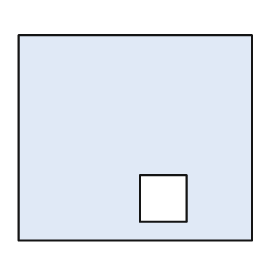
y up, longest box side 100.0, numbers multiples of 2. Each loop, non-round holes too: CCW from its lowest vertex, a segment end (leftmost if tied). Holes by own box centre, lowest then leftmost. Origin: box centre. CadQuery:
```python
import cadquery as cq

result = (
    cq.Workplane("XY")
    .moveTo(-50.0, -44.0)
    .lineTo(50.0, -44.0)
    .lineTo(50.0, 44.0)
    .lineTo(-50.0, 44.0)
    .close()
    .moveTo(2.0, -36.0)
    .lineTo(22.0, -36.0)
    .lineTo(22.0, -16.0)
    .lineTo(2.0, -16.0)
    .close()
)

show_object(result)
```